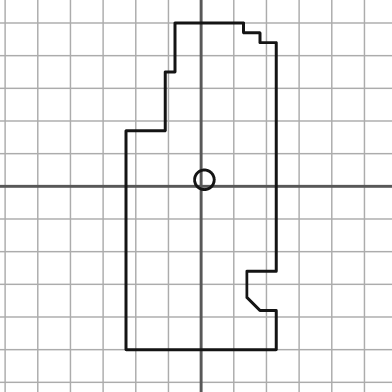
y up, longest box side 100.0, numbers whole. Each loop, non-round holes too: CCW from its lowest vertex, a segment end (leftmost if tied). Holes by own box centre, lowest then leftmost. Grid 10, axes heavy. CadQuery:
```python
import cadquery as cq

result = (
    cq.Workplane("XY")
    .moveTo(-23.0, -50.0)
    .lineTo(23.0, -50.0)
    .lineTo(23.0, -38.0)
    .lineTo(18.0, -38.0)
    .lineTo(14.0, -34.0)
    .lineTo(14.0, -26.0)
    .lineTo(23.0, -26.0)
    .lineTo(23.0, 44.0)
    .lineTo(18.0, 44.0)
    .lineTo(18.0, 47.0)
    .lineTo(13.0, 47.0)
    .lineTo(13.0, 50.0)
    .lineTo(-8.0, 50.0)
    .lineTo(-8.0, 35.0)
    .lineTo(-11.0, 35.0)
    .lineTo(-11.0, 17.0)
    .lineTo(-23.0, 17.0)
    .close()
    .moveTo(1.0, 2.0)
    .circle(3.0)
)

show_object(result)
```